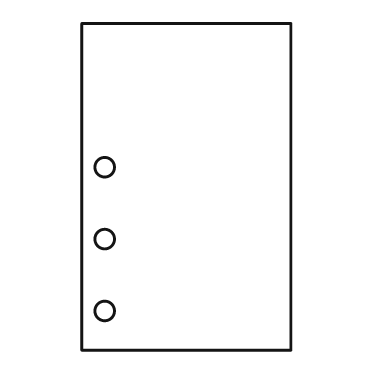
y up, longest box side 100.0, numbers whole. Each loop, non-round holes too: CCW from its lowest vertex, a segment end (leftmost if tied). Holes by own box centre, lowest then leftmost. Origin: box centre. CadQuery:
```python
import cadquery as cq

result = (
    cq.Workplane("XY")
    .moveTo(-32.0, -50.0)
    .lineTo(32.0, -50.0)
    .lineTo(32.0, 50.0)
    .lineTo(-32.0, 50.0)
    .close()
    .moveTo(-25.0, -38.0)
    .circle(3.0)
    .moveTo(-25.0, -16.0)
    .circle(3.0)
    .moveTo(-25.0, 6.0)
    .circle(3.0)
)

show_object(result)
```